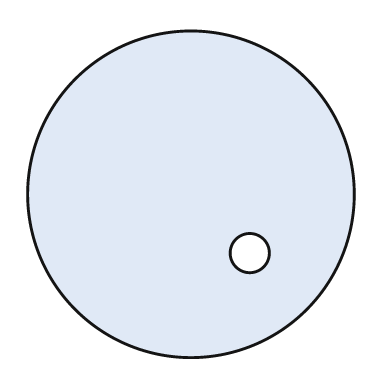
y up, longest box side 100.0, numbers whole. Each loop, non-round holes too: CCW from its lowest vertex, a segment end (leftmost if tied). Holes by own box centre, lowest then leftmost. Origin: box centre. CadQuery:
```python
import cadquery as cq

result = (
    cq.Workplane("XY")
    .moveTo(0.0, 0.0)
    .circle(50.0)
    .moveTo(18.0, -18.0)
    .circle(6.0)
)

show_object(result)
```